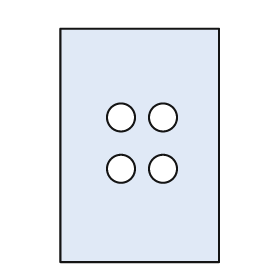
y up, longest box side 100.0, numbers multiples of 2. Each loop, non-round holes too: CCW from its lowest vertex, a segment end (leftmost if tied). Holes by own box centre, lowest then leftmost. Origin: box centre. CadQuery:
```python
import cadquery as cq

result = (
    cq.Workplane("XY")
    .moveTo(-34.0, -50.0)
    .lineTo(34.0, -50.0)
    .lineTo(34.0, 50.0)
    .lineTo(-34.0, 50.0)
    .close()
    .moveTo(-8.0, -10.0)
    .circle(6.0)
    .moveTo(10.0, -10.0)
    .circle(6.0)
    .moveTo(-8.0, 12.0)
    .circle(6.0)
    .moveTo(10.0, 12.0)
    .circle(6.0)
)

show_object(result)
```